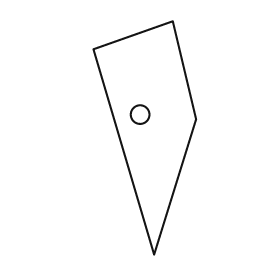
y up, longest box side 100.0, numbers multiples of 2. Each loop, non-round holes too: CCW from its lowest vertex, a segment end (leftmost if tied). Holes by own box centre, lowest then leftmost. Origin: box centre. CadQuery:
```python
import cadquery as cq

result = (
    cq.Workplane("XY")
    .moveTo(4.0, -50.0)
    .lineTo(22.0, 8.0)
    .lineTo(12.0, 50.0)
    .lineTo(-22.0, 38.0)
    .close()
    .moveTo(-2.0, 10.0)
    .circle(4.0)
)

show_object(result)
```